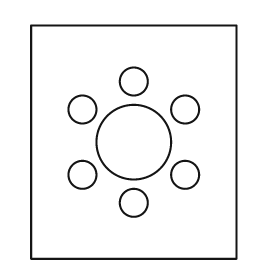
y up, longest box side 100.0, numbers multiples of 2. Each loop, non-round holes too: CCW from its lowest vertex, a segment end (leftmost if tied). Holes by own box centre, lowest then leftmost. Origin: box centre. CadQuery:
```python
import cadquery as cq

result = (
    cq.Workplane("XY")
    .moveTo(-44.0, -50.0)
    .lineTo(44.0, -50.0)
    .lineTo(44.0, 50.0)
    .lineTo(-44.0, 50.0)
    .close()
    .moveTo(0.0, -26.0)
    .circle(6.0)
    .moveTo(-22.0, -14.0)
    .circle(6.0)
    .moveTo(22.0, -14.0)
    .circle(6.0)
    .moveTo(0.0, 0.0)
    .circle(16.0)
    .moveTo(-22.0, 14.0)
    .circle(6.0)
    .moveTo(22.0, 14.0)
    .circle(6.0)
    .moveTo(0.0, 26.0)
    .circle(6.0)
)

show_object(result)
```